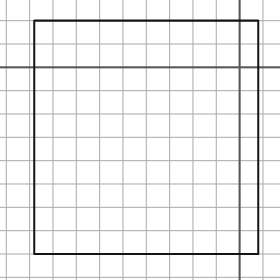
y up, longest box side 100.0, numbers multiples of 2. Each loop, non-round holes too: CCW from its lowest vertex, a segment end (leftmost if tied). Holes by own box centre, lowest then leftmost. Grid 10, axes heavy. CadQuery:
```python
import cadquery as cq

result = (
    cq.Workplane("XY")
    .moveTo(-88.0, -80.0)
    .lineTo(8.0, -80.0)
    .lineTo(8.0, 20.0)
    .lineTo(-88.0, 20.0)
    .close()
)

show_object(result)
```